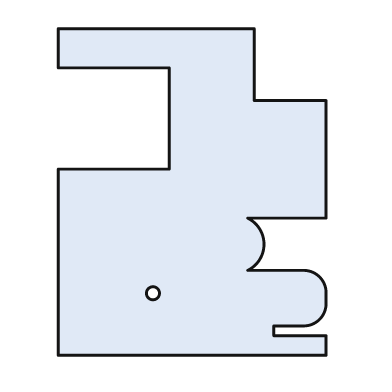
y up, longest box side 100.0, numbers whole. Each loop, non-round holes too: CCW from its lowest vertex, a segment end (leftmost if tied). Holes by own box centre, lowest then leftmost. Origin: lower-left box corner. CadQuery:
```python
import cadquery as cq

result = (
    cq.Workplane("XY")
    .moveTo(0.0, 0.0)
    .lineTo(82.0, 0.0)
    .lineTo(82.0, 6.0)
    .lineTo(66.0, 6.0)
    .lineTo(66.0, 9.0)
    .lineTo(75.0, 9.0)
    .threePointArc((80.0, 11.0), (82.0, 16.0))
    .lineTo(82.0, 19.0)
    .threePointArc((80.0, 24.0), (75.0, 26.0))
    .lineTo(58.0, 26.0)
    .threePointArc((63.0, 34.0), (58.0, 42.0))
    .lineTo(82.0, 42.0)
    .lineTo(82.0, 78.0)
    .lineTo(60.0, 78.0)
    .lineTo(60.0, 100.0)
    .lineTo(0.0, 100.0)
    .lineTo(0.0, 88.0)
    .lineTo(34.0, 88.0)
    .lineTo(34.0, 57.0)
    .lineTo(0.0, 57.0)
    .close()
    .moveTo(29.0, 19.0)
    .circle(2.0)
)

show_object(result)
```